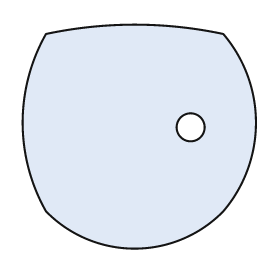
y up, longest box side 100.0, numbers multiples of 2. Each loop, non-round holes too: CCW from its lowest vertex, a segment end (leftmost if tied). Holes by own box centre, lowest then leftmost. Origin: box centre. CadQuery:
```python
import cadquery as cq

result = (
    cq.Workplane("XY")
    .moveTo(-40.0, -32.0)
    .threePointArc((-2.0, -48.0), (36.0, -32.0))
    .threePointArc((50.0, 6.0), (36.0, 44.0))
    .threePointArc((-2.0, 48.0), (-40.0, 44.0))
    .threePointArc((-50.0, 6.0), (-40.0, -32.0))
    .close()
    .moveTo(22.0, 4.0)
    .circle(6.0)
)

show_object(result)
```